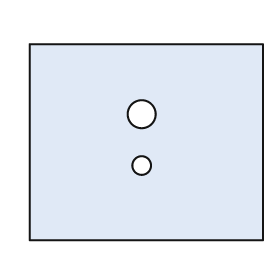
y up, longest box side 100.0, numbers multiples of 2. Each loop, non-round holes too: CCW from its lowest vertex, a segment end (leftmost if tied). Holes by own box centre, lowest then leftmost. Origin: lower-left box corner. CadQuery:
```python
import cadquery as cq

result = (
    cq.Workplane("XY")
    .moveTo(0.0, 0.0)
    .lineTo(100.0, 0.0)
    .lineTo(100.0, 84.0)
    .lineTo(0.0, 84.0)
    .close()
    .moveTo(48.0, 32.0)
    .circle(4.0)
    .moveTo(48.0, 54.0)
    .circle(6.0)
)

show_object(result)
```